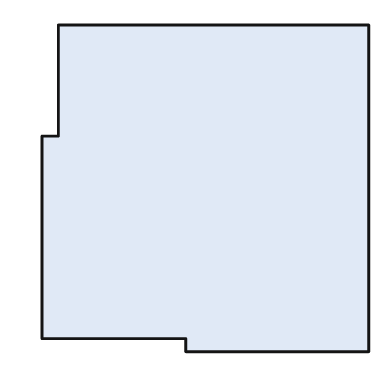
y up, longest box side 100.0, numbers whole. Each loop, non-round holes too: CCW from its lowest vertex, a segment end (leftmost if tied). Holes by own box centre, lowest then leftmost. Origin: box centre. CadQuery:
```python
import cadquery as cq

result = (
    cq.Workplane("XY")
    .moveTo(-6.0, -50.0)
    .lineTo(50.0, -50.0)
    .lineTo(50.0, 50.0)
    .lineTo(-45.0, 50.0)
    .lineTo(-45.0, 16.0)
    .lineTo(-50.0, 16.0)
    .lineTo(-50.0, -46.0)
    .lineTo(-6.0, -46.0)
    .close()
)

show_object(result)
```